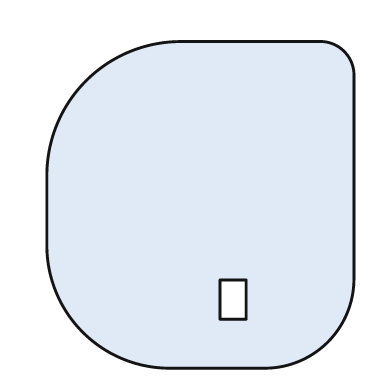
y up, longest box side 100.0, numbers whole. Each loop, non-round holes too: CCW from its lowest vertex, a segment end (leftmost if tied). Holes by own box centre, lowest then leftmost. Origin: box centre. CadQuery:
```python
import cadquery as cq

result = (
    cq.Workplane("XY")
    .moveTo(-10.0, -50.0)
    .lineTo(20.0, -50.0)
    .threePointArc((39.0, -42.0), (47.0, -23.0))
    .lineTo(47.0, 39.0)
    .threePointArc((44.0, 47.0), (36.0, 50.0))
    .lineTo(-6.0, 50.0)
    .threePointArc((-35.0, 38.0), (-47.0, 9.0))
    .lineTo(-47.0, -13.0)
    .threePointArc((-36.0, -39.0), (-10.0, -50.0))
    .close()
    .moveTo(6.0, -35.0)
    .lineTo(14.0, -35.0)
    .lineTo(14.0, -23.0)
    .lineTo(6.0, -23.0)
    .close()
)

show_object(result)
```